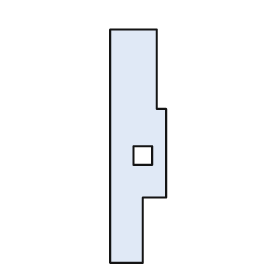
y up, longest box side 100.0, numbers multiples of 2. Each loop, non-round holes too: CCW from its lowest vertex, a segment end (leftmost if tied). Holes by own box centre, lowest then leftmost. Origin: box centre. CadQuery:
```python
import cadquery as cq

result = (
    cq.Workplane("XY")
    .moveTo(-12.0, -50.0)
    .lineTo(2.0, -50.0)
    .lineTo(2.0, -22.0)
    .lineTo(12.0, -22.0)
    .lineTo(12.0, 16.0)
    .lineTo(8.0, 16.0)
    .lineTo(8.0, 50.0)
    .lineTo(-12.0, 50.0)
    .close()
    .moveTo(-2.0, -8.0)
    .lineTo(6.0, -8.0)
    .lineTo(6.0, 0.0)
    .lineTo(-2.0, 0.0)
    .close()
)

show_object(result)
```